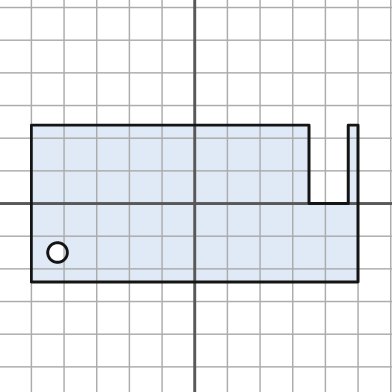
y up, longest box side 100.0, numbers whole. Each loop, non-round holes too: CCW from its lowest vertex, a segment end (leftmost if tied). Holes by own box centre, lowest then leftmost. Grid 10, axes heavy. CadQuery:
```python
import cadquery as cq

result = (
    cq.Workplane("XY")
    .moveTo(-50.0, -24.0)
    .lineTo(50.0, -24.0)
    .lineTo(50.0, 24.0)
    .lineTo(47.0, 24.0)
    .lineTo(47.0, 0.0)
    .lineTo(35.0, 0.0)
    .lineTo(35.0, 24.0)
    .lineTo(-50.0, 24.0)
    .close()
    .moveTo(-42.0, -15.0)
    .circle(3.0)
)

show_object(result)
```